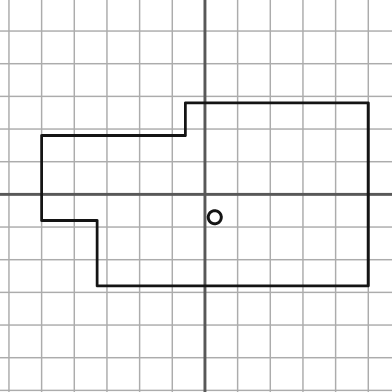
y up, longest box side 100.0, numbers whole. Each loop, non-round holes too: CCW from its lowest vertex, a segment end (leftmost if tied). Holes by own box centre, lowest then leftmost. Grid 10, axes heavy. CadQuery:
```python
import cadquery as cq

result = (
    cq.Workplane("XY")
    .moveTo(-33.0, -28.0)
    .lineTo(50.0, -28.0)
    .lineTo(50.0, 28.0)
    .lineTo(-6.0, 28.0)
    .lineTo(-6.0, 18.0)
    .lineTo(-50.0, 18.0)
    .lineTo(-50.0, -8.0)
    .lineTo(-33.0, -8.0)
    .close()
    .moveTo(3.0, -7.0)
    .circle(2.0)
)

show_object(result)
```